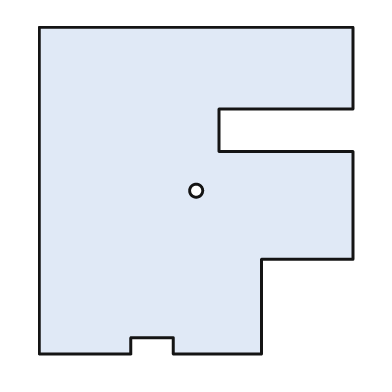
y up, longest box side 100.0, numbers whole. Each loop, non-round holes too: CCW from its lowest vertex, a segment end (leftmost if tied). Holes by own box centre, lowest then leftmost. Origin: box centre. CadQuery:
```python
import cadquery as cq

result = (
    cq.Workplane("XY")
    .moveTo(-48.0, -50.0)
    .lineTo(-20.0, -50.0)
    .lineTo(-20.0, -45.0)
    .lineTo(-7.0, -45.0)
    .lineTo(-7.0, -50.0)
    .lineTo(20.0, -50.0)
    .lineTo(20.0, -21.0)
    .lineTo(48.0, -21.0)
    .lineTo(48.0, 12.0)
    .lineTo(7.0, 12.0)
    .lineTo(7.0, 25.0)
    .lineTo(48.0, 25.0)
    .lineTo(48.0, 50.0)
    .lineTo(-48.0, 50.0)
    .close()
    .moveTo(0.0, 0.0)
    .circle(2.0)
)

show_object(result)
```